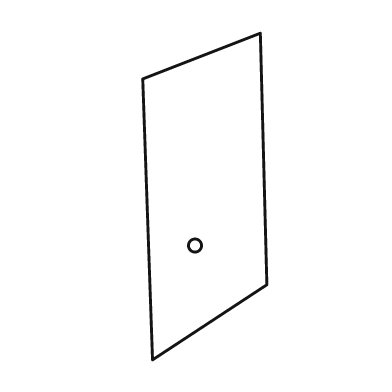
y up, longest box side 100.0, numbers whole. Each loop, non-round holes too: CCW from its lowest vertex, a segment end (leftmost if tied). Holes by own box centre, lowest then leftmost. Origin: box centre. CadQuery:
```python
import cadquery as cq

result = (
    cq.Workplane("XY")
    .moveTo(-16.0, -50.0)
    .lineTo(19.0, -27.0)
    .lineTo(17.0, 50.0)
    .lineTo(-19.0, 36.0)
    .close()
    .moveTo(-3.0, -15.0)
    .circle(2.0)
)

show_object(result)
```